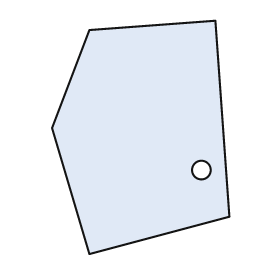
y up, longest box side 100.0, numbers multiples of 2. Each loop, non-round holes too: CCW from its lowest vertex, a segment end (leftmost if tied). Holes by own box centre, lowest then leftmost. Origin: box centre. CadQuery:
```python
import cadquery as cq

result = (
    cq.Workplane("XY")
    .moveTo(-22.0, -50.0)
    .lineTo(38.0, -34.0)
    .lineTo(32.0, 50.0)
    .lineTo(-22.0, 46.0)
    .lineTo(-38.0, 4.0)
    .close()
    .moveTo(26.0, -14.0)
    .circle(4.0)
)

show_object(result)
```